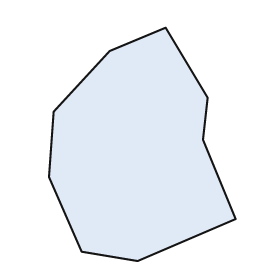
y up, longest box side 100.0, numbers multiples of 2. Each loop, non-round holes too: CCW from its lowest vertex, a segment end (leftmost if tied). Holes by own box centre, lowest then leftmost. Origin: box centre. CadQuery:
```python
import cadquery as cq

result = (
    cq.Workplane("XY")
    .moveTo(-2.0, -50.0)
    .lineTo(40.0, -32.0)
    .lineTo(26.0, 2.0)
    .lineTo(28.0, 20.0)
    .lineTo(10.0, 50.0)
    .lineTo(-14.0, 40.0)
    .lineTo(-38.0, 14.0)
    .lineTo(-40.0, -14.0)
    .lineTo(-26.0, -46.0)
    .close()
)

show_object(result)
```